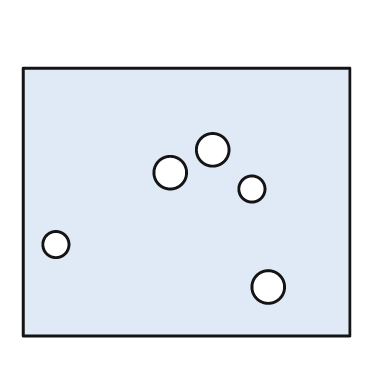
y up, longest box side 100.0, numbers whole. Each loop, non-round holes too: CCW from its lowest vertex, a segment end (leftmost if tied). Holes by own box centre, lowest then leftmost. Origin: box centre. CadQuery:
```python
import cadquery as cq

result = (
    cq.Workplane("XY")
    .moveTo(-50.0, -41.0)
    .lineTo(50.0, -41.0)
    .lineTo(50.0, 41.0)
    .lineTo(-50.0, 41.0)
    .close()
    .moveTo(25.0, -26.0)
    .circle(5.0)
    .moveTo(-40.0, -13.0)
    .circle(4.0)
    .moveTo(20.0, 4.0)
    .circle(4.0)
    .moveTo(-5.0, 9.0)
    .circle(5.0)
    .moveTo(8.0, 16.0)
    .circle(5.0)
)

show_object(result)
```